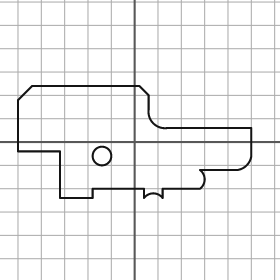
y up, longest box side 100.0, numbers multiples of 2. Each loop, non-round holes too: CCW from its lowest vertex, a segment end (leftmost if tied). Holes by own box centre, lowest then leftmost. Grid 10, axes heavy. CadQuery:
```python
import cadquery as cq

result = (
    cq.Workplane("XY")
    .moveTo(-32.0, -24.0)
    .lineTo(-18.0, -24.0)
    .lineTo(-18.0, -20.0)
    .lineTo(4.0, -20.0)
    .lineTo(4.0, -24.0)
    .threePointArc((8.0, -22.0), (12.0, -24.0))
    .lineTo(12.0, -20.0)
    .lineTo(28.0, -20.0)
    .threePointArc((30.0, -16.0), (28.0, -12.0))
    .lineTo(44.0, -12.0)
    .threePointArc((48.0, -10.0), (50.0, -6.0))
    .lineTo(50.0, 6.0)
    .lineTo(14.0, 6.0)
    .threePointArc((8.0, 8.0), (6.0, 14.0))
    .lineTo(6.0, 20.0)
    .lineTo(2.0, 24.0)
    .lineTo(-44.0, 24.0)
    .lineTo(-50.0, 18.0)
    .lineTo(-50.0, -4.0)
    .lineTo(-32.0, -4.0)
    .close()
    .moveTo(-14.0, -6.0)
    .circle(4.0)
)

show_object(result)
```